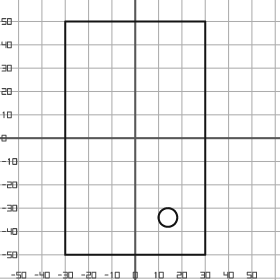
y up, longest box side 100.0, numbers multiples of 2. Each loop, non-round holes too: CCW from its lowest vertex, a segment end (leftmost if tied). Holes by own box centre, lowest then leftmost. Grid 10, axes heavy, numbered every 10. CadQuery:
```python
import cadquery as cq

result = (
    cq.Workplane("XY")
    .moveTo(-30.0, -50.0)
    .lineTo(30.0, -50.0)
    .lineTo(30.0, 50.0)
    .lineTo(-30.0, 50.0)
    .close()
    .moveTo(14.0, -34.0)
    .circle(4.0)
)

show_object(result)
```